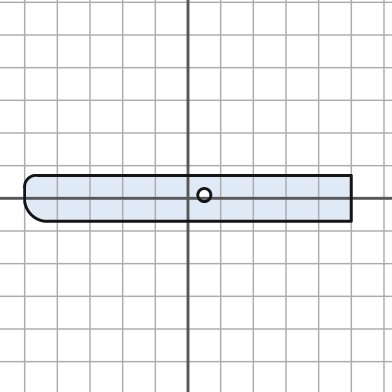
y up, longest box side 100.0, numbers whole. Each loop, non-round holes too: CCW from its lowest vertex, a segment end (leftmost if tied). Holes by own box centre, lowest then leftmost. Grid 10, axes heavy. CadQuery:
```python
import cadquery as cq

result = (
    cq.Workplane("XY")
    .moveTo(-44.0, -7.0)
    .lineTo(50.0, -7.0)
    .lineTo(50.0, 7.0)
    .lineTo(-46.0, 7.0)
    .threePointArc((-49.0, 6.0), (-50.0, 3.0))
    .lineTo(-50.0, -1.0)
    .threePointArc((-48.0, -5.0), (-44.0, -7.0))
    .close()
    .moveTo(5.0, 1.0)
    .circle(2.0)
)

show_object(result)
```